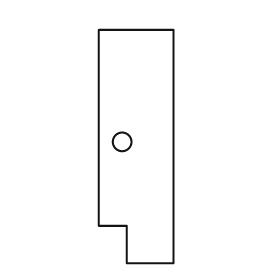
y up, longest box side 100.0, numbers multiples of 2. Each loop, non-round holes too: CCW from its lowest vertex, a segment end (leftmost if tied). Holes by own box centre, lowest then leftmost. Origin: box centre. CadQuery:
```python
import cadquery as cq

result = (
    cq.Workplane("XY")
    .moveTo(-4.0, -50.0)
    .lineTo(16.0, -50.0)
    .lineTo(16.0, 50.0)
    .lineTo(-16.0, 50.0)
    .lineTo(-16.0, -34.0)
    .lineTo(-4.0, -34.0)
    .close()
    .moveTo(-6.0, 2.0)
    .circle(4.0)
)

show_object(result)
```